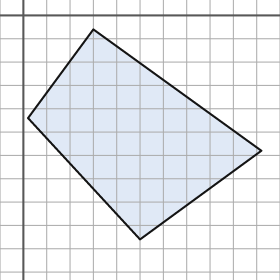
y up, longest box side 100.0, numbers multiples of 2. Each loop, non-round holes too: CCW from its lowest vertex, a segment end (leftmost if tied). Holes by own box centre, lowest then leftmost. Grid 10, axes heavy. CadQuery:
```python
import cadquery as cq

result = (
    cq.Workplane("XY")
    .moveTo(50.0, -96.0)
    .lineTo(102.0, -58.0)
    .lineTo(30.0, -6.0)
    .lineTo(2.0, -44.0)
    .close()
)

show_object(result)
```